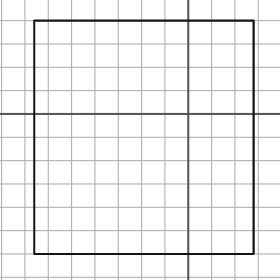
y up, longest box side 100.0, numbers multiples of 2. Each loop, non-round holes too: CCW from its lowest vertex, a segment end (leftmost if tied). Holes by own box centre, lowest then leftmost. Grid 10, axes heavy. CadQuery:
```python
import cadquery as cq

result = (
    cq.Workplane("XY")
    .moveTo(-66.0, -60.0)
    .lineTo(28.0, -60.0)
    .lineTo(28.0, 40.0)
    .lineTo(-66.0, 40.0)
    .close()
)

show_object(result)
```